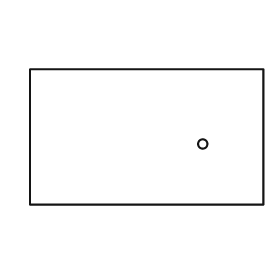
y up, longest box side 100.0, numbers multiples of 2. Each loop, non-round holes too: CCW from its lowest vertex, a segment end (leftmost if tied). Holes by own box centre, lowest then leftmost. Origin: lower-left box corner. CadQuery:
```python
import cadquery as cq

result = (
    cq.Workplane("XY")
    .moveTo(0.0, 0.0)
    .lineTo(100.0, 0.0)
    .lineTo(100.0, 58.0)
    .lineTo(0.0, 58.0)
    .close()
    .moveTo(74.0, 26.0)
    .circle(2.0)
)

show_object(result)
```